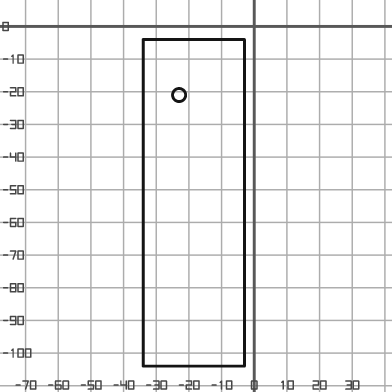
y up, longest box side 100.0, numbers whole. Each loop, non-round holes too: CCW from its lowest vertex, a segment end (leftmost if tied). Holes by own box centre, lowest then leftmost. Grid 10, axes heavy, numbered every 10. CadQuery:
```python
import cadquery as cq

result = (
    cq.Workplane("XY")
    .moveTo(-34.0, -104.0)
    .lineTo(-3.0, -104.0)
    .lineTo(-3.0, -4.0)
    .lineTo(-34.0, -4.0)
    .close()
    .moveTo(-23.0, -21.0)
    .circle(2.0)
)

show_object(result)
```